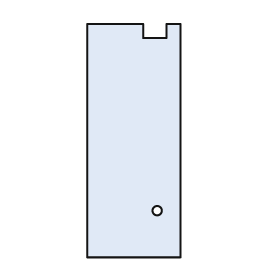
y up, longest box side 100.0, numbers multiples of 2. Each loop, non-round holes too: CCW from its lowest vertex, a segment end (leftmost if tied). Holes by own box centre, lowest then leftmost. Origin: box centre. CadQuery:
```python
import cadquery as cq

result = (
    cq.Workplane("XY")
    .moveTo(-20.0, -50.0)
    .lineTo(20.0, -50.0)
    .lineTo(20.0, 50.0)
    .lineTo(14.0, 50.0)
    .lineTo(14.0, 44.0)
    .lineTo(4.0, 44.0)
    .lineTo(4.0, 50.0)
    .lineTo(-20.0, 50.0)
    .close()
    .moveTo(10.0, -30.0)
    .circle(2.0)
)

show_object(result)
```